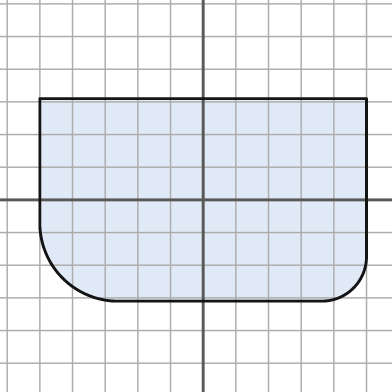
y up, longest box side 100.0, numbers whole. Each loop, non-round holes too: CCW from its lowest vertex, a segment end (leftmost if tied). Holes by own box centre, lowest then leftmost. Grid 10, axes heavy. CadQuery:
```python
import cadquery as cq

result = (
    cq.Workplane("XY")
    .moveTo(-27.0, -31.0)
    .lineTo(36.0, -31.0)
    .threePointArc((46.0, -27.0), (50.0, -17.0))
    .lineTo(50.0, 31.0)
    .lineTo(-50.0, 31.0)
    .lineTo(-50.0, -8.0)
    .threePointArc((-43.0, -24.0), (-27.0, -31.0))
    .close()
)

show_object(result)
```